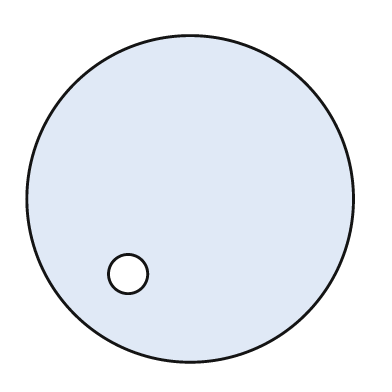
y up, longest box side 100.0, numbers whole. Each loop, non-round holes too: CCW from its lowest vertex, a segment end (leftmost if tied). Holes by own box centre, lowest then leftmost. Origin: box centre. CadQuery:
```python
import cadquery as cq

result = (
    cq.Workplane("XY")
    .moveTo(0.0, 0.0)
    .circle(50.0)
    .moveTo(-19.0, -23.0)
    .circle(6.0)
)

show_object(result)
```